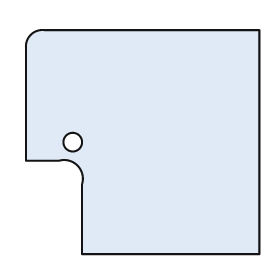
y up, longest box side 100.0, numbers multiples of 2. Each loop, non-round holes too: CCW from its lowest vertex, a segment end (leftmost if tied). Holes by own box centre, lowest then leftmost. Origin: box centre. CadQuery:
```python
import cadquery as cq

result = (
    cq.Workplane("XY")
    .moveTo(-26.0, -48.0)
    .lineTo(50.0, -48.0)
    .lineTo(50.0, 48.0)
    .lineTo(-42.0, 48.0)
    .threePointArc((-48.0, 46.0), (-50.0, 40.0))
    .lineTo(-50.0, -8.0)
    .lineTo(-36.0, -8.0)
    .threePointArc((-28.0, -10.0), (-26.0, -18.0))
    .close()
    .moveTo(-30.0, 0.0)
    .circle(4.0)
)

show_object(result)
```